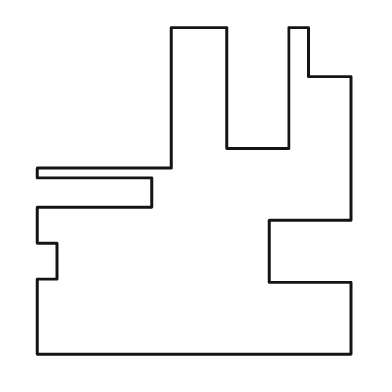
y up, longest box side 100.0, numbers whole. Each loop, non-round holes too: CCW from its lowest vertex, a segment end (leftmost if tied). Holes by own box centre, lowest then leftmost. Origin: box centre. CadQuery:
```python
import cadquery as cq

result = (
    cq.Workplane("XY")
    .moveTo(-48.0, -50.0)
    .lineTo(48.0, -50.0)
    .lineTo(48.0, -28.0)
    .lineTo(23.0, -28.0)
    .lineTo(23.0, -9.0)
    .lineTo(48.0, -9.0)
    .lineTo(48.0, 35.0)
    .lineTo(35.0, 35.0)
    .lineTo(35.0, 50.0)
    .lineTo(29.0, 50.0)
    .lineTo(29.0, 13.0)
    .lineTo(10.0, 13.0)
    .lineTo(10.0, 50.0)
    .lineTo(-7.0, 50.0)
    .lineTo(-7.0, 7.0)
    .lineTo(-48.0, 7.0)
    .lineTo(-48.0, 4.0)
    .lineTo(-13.0, 4.0)
    .lineTo(-13.0, -5.0)
    .lineTo(-48.0, -5.0)
    .lineTo(-48.0, -16.0)
    .lineTo(-42.0, -16.0)
    .lineTo(-42.0, -27.0)
    .lineTo(-48.0, -27.0)
    .close()
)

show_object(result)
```